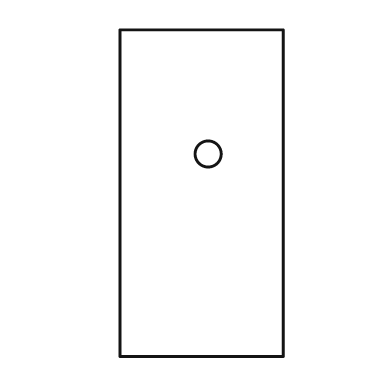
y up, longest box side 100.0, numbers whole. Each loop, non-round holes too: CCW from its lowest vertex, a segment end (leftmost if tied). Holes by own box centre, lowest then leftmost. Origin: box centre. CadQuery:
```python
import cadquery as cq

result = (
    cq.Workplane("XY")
    .moveTo(-25.0, -50.0)
    .lineTo(25.0, -50.0)
    .lineTo(25.0, 50.0)
    .lineTo(-25.0, 50.0)
    .close()
    .moveTo(2.0, 12.0)
    .circle(4.0)
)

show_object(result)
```